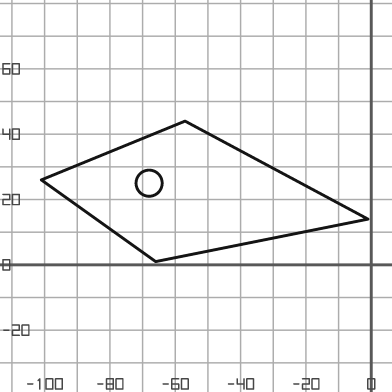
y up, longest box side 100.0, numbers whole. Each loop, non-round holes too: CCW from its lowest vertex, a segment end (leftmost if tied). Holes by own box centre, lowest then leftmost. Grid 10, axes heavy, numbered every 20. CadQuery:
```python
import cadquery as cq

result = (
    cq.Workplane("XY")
    .moveTo(-66.0, 1.0)
    .lineTo(-1.0, 14.0)
    .lineTo(-57.0, 44.0)
    .lineTo(-101.0, 26.0)
    .close()
    .moveTo(-68.0, 25.0)
    .circle(4.0)
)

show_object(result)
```